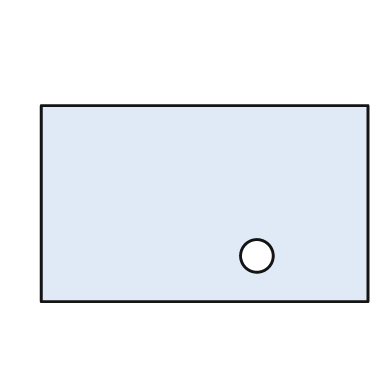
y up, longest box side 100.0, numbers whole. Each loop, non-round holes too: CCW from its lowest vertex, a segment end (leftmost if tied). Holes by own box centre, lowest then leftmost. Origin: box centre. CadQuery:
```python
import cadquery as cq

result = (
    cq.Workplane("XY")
    .moveTo(-50.0, -30.0)
    .lineTo(50.0, -30.0)
    .lineTo(50.0, 30.0)
    .lineTo(-50.0, 30.0)
    .close()
    .moveTo(16.0, -16.0)
    .circle(5.0)
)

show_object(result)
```